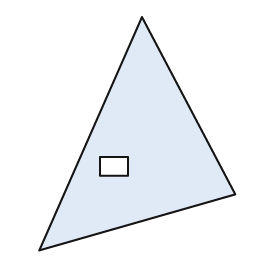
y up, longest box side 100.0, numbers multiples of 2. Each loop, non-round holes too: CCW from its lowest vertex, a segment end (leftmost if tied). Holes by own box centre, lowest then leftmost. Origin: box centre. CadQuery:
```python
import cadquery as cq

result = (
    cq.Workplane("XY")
    .moveTo(-42.0, -50.0)
    .lineTo(42.0, -26.0)
    .lineTo(2.0, 50.0)
    .close()
    .moveTo(-16.0, -18.0)
    .lineTo(-4.0, -18.0)
    .lineTo(-4.0, -10.0)
    .lineTo(-16.0, -10.0)
    .close()
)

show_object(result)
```